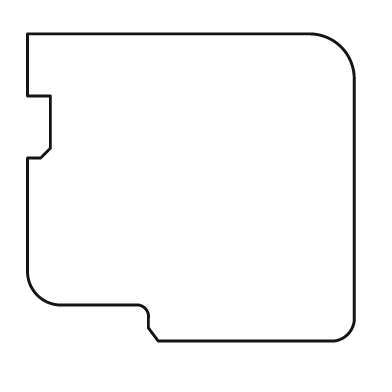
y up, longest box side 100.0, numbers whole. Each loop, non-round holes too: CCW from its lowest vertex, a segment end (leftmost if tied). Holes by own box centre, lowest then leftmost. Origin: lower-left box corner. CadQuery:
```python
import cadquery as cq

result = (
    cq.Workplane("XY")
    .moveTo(40.0, 0.0)
    .lineTo(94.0, 0.0)
    .threePointArc((98.0, 2.0), (100.0, 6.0))
    .lineTo(100.0, 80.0)
    .threePointArc((96.0, 90.0), (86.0, 94.0))
    .lineTo(0.0, 94.0)
    .lineTo(0.0, 75.0)
    .lineTo(7.0, 75.0)
    .lineTo(7.0, 59.0)
    .lineTo(4.0, 56.0)
    .lineTo(0.0, 56.0)
    .lineTo(0.0, 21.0)
    .threePointArc((3.0, 14.0), (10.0, 11.0))
    .lineTo(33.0, 11.0)
    .threePointArc((36.0, 10.0), (37.0, 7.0))
    .lineTo(37.0, 4.0)
    .close()
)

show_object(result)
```